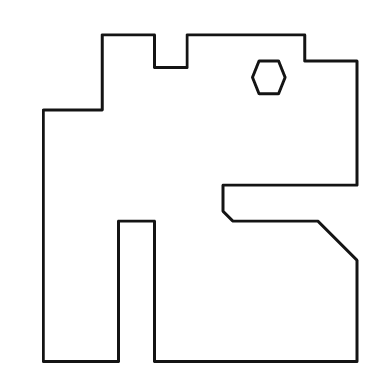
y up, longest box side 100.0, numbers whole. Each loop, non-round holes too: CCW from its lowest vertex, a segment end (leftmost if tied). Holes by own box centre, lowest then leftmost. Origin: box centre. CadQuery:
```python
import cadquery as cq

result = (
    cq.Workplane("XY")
    .moveTo(-48.0, -50.0)
    .lineTo(-25.0, -50.0)
    .lineTo(-25.0, -7.0)
    .lineTo(-14.0, -7.0)
    .lineTo(-14.0, -50.0)
    .lineTo(48.0, -50.0)
    .lineTo(48.0, -19.0)
    .lineTo(36.0, -7.0)
    .lineTo(10.0, -7.0)
    .lineTo(7.0, -4.0)
    .lineTo(7.0, 4.0)
    .lineTo(48.0, 4.0)
    .lineTo(48.0, 42.0)
    .lineTo(32.0, 42.0)
    .lineTo(32.0, 50.0)
    .lineTo(-4.0, 50.0)
    .lineTo(-4.0, 40.0)
    .lineTo(-14.0, 40.0)
    .lineTo(-14.0, 50.0)
    .lineTo(-30.0, 50.0)
    .lineTo(-30.0, 27.0)
    .lineTo(-48.0, 27.0)
    .close()
    .moveTo(18.0, 32.0)
    .lineTo(24.0, 32.0)
    .lineTo(26.0, 37.0)
    .lineTo(24.0, 42.0)
    .lineTo(18.0, 42.0)
    .lineTo(16.0, 37.0)
    .close()
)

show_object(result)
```